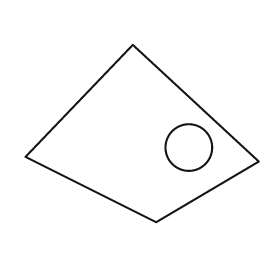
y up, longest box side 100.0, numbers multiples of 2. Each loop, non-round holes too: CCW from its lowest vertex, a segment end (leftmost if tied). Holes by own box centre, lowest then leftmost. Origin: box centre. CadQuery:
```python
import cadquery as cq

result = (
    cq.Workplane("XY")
    .moveTo(6.0, -38.0)
    .lineTo(50.0, -12.0)
    .lineTo(-4.0, 38.0)
    .lineTo(-50.0, -10.0)
    .close()
    .moveTo(20.0, -6.0)
    .circle(10.0)
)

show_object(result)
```